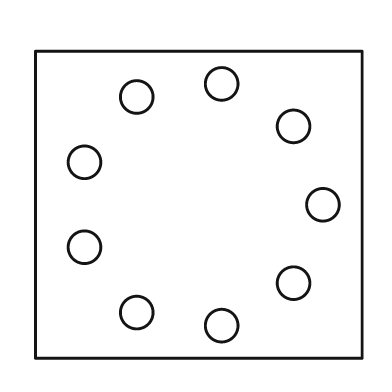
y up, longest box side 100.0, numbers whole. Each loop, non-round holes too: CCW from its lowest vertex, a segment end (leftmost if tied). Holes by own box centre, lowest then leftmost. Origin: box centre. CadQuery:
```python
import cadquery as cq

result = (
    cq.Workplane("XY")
    .moveTo(-50.0, -47.0)
    .lineTo(50.0, -47.0)
    .lineTo(50.0, 47.0)
    .lineTo(-50.0, 47.0)
    .close()
    .moveTo(7.0, -37.0)
    .circle(5.0)
    .moveTo(-19.0, -33.0)
    .circle(5.0)
    .moveTo(29.0, -24.0)
    .circle(5.0)
    .moveTo(-35.0, -13.0)
    .circle(5.0)
    .moveTo(38.0, 0.0)
    .circle(5.0)
    .moveTo(-35.0, 13.0)
    .circle(5.0)
    .moveTo(29.0, 24.0)
    .circle(5.0)
    .moveTo(-19.0, 33.0)
    .circle(5.0)
    .moveTo(7.0, 37.0)
    .circle(5.0)
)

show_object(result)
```